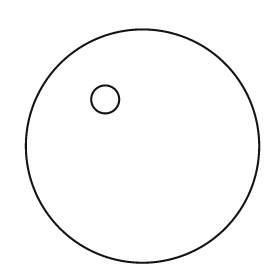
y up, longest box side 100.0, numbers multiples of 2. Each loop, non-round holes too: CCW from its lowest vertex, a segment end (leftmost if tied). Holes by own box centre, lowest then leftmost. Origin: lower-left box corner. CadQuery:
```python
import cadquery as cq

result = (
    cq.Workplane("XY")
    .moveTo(50.0, 50.0)
    .circle(50.0)
    .moveTo(34.0, 70.0)
    .circle(6.0)
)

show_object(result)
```